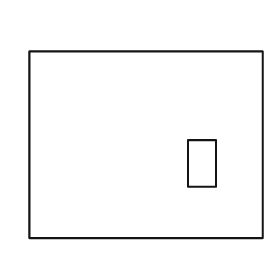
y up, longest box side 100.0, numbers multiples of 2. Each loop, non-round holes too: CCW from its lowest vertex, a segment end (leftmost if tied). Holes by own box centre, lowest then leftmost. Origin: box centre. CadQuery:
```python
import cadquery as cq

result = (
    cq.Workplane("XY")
    .moveTo(-50.0, -40.0)
    .lineTo(50.0, -40.0)
    .lineTo(50.0, 40.0)
    .lineTo(-50.0, 40.0)
    .close()
    .moveTo(18.0, -18.0)
    .lineTo(30.0, -18.0)
    .lineTo(30.0, 2.0)
    .lineTo(18.0, 2.0)
    .close()
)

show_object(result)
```